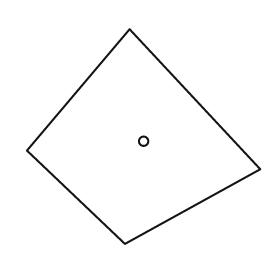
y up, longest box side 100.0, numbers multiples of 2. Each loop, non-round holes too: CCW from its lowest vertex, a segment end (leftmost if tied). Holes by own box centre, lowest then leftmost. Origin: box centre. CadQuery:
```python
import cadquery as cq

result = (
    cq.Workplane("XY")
    .moveTo(-8.0, -46.0)
    .lineTo(50.0, -14.0)
    .lineTo(-6.0, 46.0)
    .lineTo(-50.0, -6.0)
    .close()
    .moveTo(0.0, -2.0)
    .circle(2.0)
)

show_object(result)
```